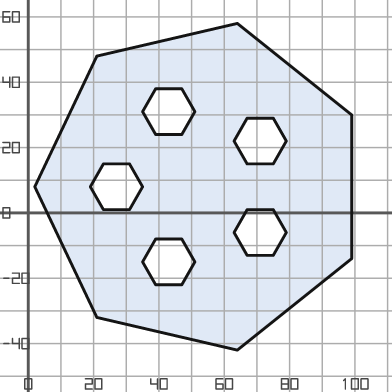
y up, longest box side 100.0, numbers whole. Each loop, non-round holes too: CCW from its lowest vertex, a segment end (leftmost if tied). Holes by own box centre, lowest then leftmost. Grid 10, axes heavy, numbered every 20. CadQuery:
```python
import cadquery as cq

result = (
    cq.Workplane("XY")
    .moveTo(64.0, -42.0)
    .lineTo(99.0, -14.0)
    .lineTo(99.0, 30.0)
    .lineTo(64.0, 58.0)
    .lineTo(21.0, 48.0)
    .lineTo(2.0, 8.0)
    .lineTo(21.0, -32.0)
    .close()
    .moveTo(39.0, -22.0)
    .lineTo(47.0, -22.0)
    .lineTo(51.0, -15.0)
    .lineTo(47.0, -8.0)
    .lineTo(39.0, -8.0)
    .lineTo(35.0, -15.0)
    .close()
    .moveTo(67.0, -13.0)
    .lineTo(75.0, -13.0)
    .lineTo(79.0, -6.0)
    .lineTo(75.0, 1.0)
    .lineTo(67.0, 1.0)
    .lineTo(63.0, -6.0)
    .close()
    .moveTo(23.0, 1.0)
    .lineTo(31.0, 1.0)
    .lineTo(35.0, 8.0)
    .lineTo(31.0, 15.0)
    .lineTo(23.0, 15.0)
    .lineTo(19.0, 8.0)
    .close()
    .moveTo(67.0, 15.0)
    .lineTo(75.0, 15.0)
    .lineTo(79.0, 22.0)
    .lineTo(75.0, 29.0)
    .lineTo(67.0, 29.0)
    .lineTo(63.0, 22.0)
    .close()
    .moveTo(39.0, 24.0)
    .lineTo(47.0, 24.0)
    .lineTo(51.0, 31.0)
    .lineTo(47.0, 38.0)
    .lineTo(39.0, 38.0)
    .lineTo(35.0, 31.0)
    .close()
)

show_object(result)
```